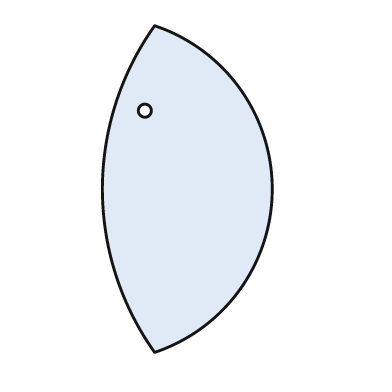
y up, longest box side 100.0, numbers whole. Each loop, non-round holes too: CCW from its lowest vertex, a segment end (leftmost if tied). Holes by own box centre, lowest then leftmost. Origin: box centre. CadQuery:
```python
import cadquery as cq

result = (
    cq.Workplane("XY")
    .moveTo(-10.0, -50.0)
    .threePointArc((26.0, 0.0), (-10.0, 50.0))
    .threePointArc((-26.0, 0.0), (-10.0, -50.0))
    .close()
    .moveTo(-13.0, 24.0)
    .circle(2.0)
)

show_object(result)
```